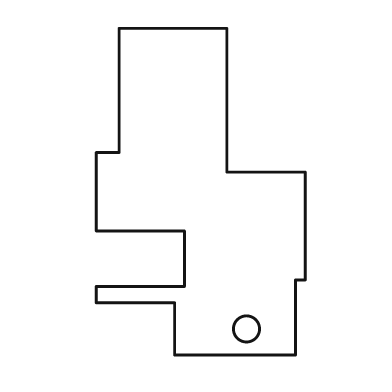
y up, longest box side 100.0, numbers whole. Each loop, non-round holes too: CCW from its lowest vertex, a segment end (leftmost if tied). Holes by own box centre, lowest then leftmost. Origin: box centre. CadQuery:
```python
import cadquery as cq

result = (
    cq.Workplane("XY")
    .moveTo(-8.0, -50.0)
    .lineTo(29.0, -50.0)
    .lineTo(29.0, -27.0)
    .lineTo(32.0, -27.0)
    .lineTo(32.0, 6.0)
    .lineTo(8.0, 6.0)
    .lineTo(8.0, 50.0)
    .lineTo(-25.0, 50.0)
    .lineTo(-25.0, 12.0)
    .lineTo(-32.0, 12.0)
    .lineTo(-32.0, -12.0)
    .lineTo(-5.0, -12.0)
    .lineTo(-5.0, -29.0)
    .lineTo(-32.0, -29.0)
    .lineTo(-32.0, -34.0)
    .lineTo(-8.0, -34.0)
    .close()
    .moveTo(14.0, -42.0)
    .circle(4.0)
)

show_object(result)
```